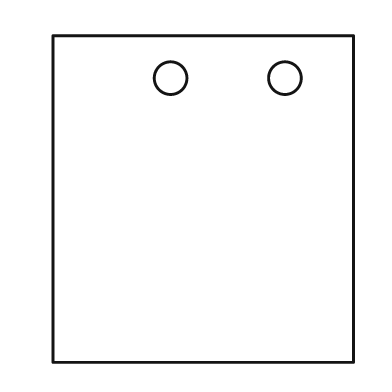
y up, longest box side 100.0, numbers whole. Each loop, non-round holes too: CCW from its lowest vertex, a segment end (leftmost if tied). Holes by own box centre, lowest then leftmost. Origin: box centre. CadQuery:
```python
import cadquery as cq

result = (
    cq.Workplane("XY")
    .moveTo(-46.0, -50.0)
    .lineTo(46.0, -50.0)
    .lineTo(46.0, 50.0)
    .lineTo(-46.0, 50.0)
    .close()
    .moveTo(-10.0, 37.0)
    .circle(5.0)
    .moveTo(25.0, 37.0)
    .circle(5.0)
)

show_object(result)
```